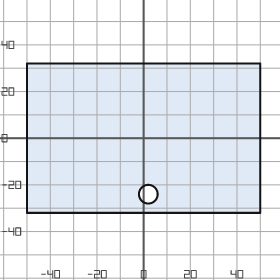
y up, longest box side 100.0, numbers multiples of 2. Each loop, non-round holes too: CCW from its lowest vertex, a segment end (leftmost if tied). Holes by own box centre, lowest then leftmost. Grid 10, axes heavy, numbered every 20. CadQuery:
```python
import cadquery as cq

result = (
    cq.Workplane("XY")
    .moveTo(-50.0, -32.0)
    .lineTo(50.0, -32.0)
    .lineTo(50.0, 32.0)
    .lineTo(-50.0, 32.0)
    .close()
    .moveTo(2.0, -24.0)
    .circle(4.0)
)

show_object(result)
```